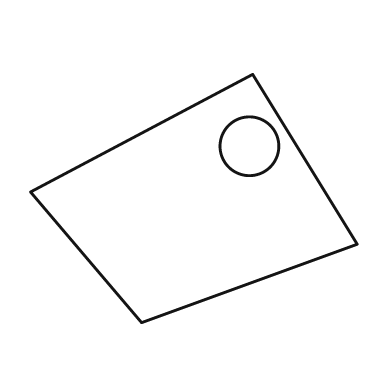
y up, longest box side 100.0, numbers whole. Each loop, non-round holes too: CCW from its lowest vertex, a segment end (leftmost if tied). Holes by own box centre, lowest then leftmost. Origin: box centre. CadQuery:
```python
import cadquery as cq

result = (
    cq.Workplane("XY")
    .moveTo(-16.0, -38.0)
    .lineTo(50.0, -14.0)
    .lineTo(18.0, 38.0)
    .lineTo(-50.0, 2.0)
    .close()
    .moveTo(17.0, 16.0)
    .circle(9.0)
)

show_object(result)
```